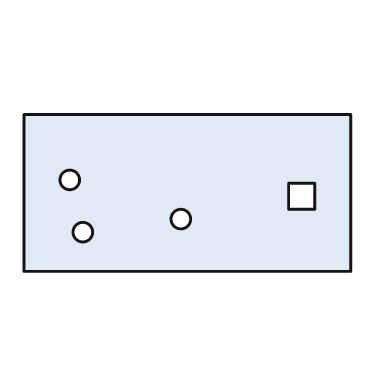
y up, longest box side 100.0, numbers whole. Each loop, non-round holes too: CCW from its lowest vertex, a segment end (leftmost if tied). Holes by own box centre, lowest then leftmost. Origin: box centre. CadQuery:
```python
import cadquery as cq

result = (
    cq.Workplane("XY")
    .moveTo(-50.0, -24.0)
    .lineTo(50.0, -24.0)
    .lineTo(50.0, 24.0)
    .lineTo(-50.0, 24.0)
    .close()
    .moveTo(-32.0, -12.0)
    .circle(3.0)
    .moveTo(-2.0, -8.0)
    .circle(3.0)
    .moveTo(31.0, -5.0)
    .lineTo(39.0, -5.0)
    .lineTo(39.0, 3.0)
    .lineTo(31.0, 3.0)
    .close()
    .moveTo(-36.0, 4.0)
    .circle(3.0)
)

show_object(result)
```